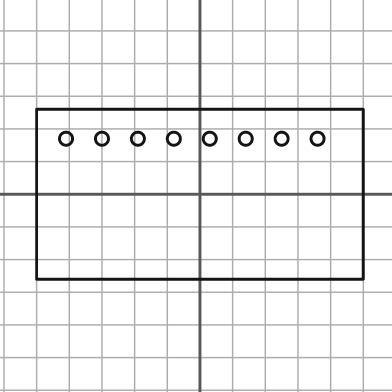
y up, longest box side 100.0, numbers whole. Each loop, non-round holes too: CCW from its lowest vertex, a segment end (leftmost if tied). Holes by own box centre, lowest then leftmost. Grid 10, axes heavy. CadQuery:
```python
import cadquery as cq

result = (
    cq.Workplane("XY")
    .moveTo(-50.0, -26.0)
    .lineTo(50.0, -26.0)
    .lineTo(50.0, 26.0)
    .lineTo(-50.0, 26.0)
    .close()
    .moveTo(-41.0, 17.0)
    .circle(2.0)
    .moveTo(-30.0, 17.0)
    .circle(2.0)
    .moveTo(-19.0, 17.0)
    .circle(2.0)
    .moveTo(-8.0, 17.0)
    .circle(2.0)
    .moveTo(3.0, 17.0)
    .circle(2.0)
    .moveTo(14.0, 17.0)
    .circle(2.0)
    .moveTo(25.0, 17.0)
    .circle(2.0)
    .moveTo(36.0, 17.0)
    .circle(2.0)
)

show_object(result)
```